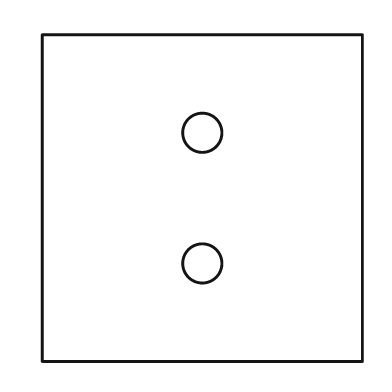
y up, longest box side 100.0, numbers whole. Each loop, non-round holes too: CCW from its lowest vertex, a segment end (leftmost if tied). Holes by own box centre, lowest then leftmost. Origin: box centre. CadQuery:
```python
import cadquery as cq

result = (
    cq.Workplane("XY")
    .moveTo(-49.0, -50.0)
    .lineTo(49.0, -50.0)
    .lineTo(49.0, 50.0)
    .lineTo(-49.0, 50.0)
    .close()
    .moveTo(0.0, -20.0)
    .circle(6.0)
    .moveTo(0.0, 20.0)
    .circle(6.0)
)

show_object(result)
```